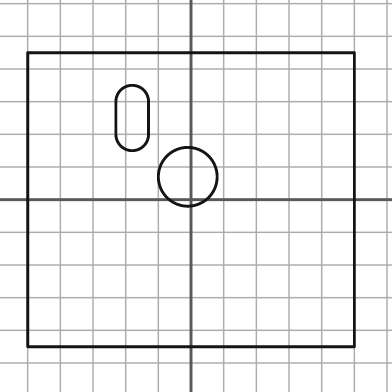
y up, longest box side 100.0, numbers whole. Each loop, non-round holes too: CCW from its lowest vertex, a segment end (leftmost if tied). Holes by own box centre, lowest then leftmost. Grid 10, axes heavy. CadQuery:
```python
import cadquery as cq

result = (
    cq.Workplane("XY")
    .moveTo(-50.0, -45.0)
    .lineTo(50.0, -45.0)
    .lineTo(50.0, 45.0)
    .lineTo(-50.0, 45.0)
    .close()
    .moveTo(-1.0, 7.0)
    .circle(9.0)
    .moveTo(-23.0, 20.0)
    .threePointArc((-18.0, 15.0), (-13.0, 20.0))
    .lineTo(-13.0, 30.0)
    .threePointArc((-18.0, 35.0), (-23.0, 30.0))
    .close()
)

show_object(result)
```